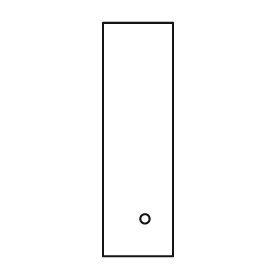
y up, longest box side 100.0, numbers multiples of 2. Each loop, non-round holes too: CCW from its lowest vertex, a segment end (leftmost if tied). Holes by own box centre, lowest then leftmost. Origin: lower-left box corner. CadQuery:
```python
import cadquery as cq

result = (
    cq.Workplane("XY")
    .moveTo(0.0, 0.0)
    .lineTo(30.0, 0.0)
    .lineTo(30.0, 100.0)
    .lineTo(0.0, 100.0)
    .close()
    .moveTo(18.0, 16.0)
    .circle(2.0)
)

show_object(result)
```